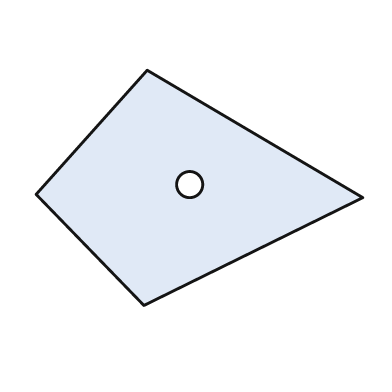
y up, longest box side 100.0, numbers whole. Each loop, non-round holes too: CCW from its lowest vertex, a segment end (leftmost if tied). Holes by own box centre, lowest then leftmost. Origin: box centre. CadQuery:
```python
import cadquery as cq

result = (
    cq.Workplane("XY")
    .moveTo(-17.0, -36.0)
    .lineTo(50.0, -3.0)
    .lineTo(-16.0, 36.0)
    .lineTo(-50.0, -2.0)
    .close()
    .moveTo(-3.0, 1.0)
    .circle(4.0)
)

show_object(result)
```